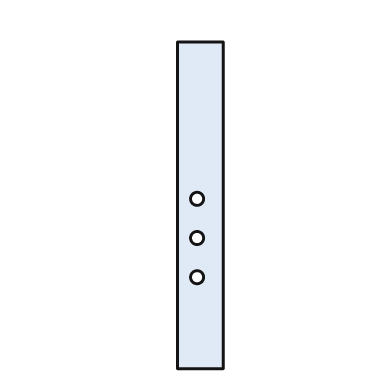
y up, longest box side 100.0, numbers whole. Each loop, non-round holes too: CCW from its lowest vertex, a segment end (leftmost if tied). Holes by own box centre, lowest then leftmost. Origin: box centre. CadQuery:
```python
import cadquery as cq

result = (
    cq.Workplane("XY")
    .moveTo(-7.0, -50.0)
    .lineTo(7.0, -50.0)
    .lineTo(7.0, 50.0)
    .lineTo(-7.0, 50.0)
    .close()
    .moveTo(-1.0, -22.0)
    .circle(2.0)
    .moveTo(-1.0, -10.0)
    .circle(2.0)
    .moveTo(-1.0, 2.0)
    .circle(2.0)
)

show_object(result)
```